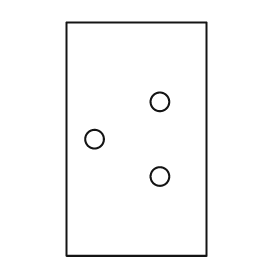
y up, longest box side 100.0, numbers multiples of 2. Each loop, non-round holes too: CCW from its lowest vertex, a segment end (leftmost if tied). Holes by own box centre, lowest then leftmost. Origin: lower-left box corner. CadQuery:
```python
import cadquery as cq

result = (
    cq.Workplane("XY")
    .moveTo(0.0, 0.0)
    .lineTo(60.0, 0.0)
    .lineTo(60.0, 100.0)
    .lineTo(0.0, 100.0)
    .close()
    .moveTo(40.0, 34.0)
    .circle(4.0)
    .moveTo(12.0, 50.0)
    .circle(4.0)
    .moveTo(40.0, 66.0)
    .circle(4.0)
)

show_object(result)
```